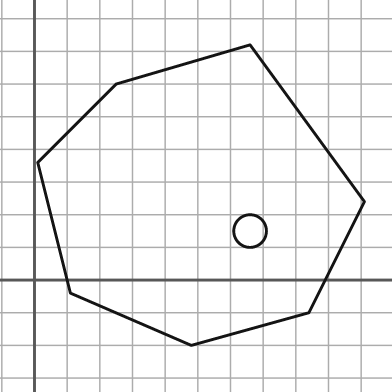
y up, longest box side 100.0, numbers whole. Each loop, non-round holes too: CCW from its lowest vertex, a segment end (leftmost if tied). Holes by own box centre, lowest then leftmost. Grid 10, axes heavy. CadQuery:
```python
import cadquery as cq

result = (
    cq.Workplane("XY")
    .moveTo(48.0, -20.0)
    .lineTo(84.0, -10.0)
    .lineTo(101.0, 24.0)
    .lineTo(66.0, 72.0)
    .lineTo(25.0, 60.0)
    .lineTo(1.0, 36.0)
    .lineTo(11.0, -4.0)
    .close()
    .moveTo(66.0, 15.0)
    .circle(5.0)
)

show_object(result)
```